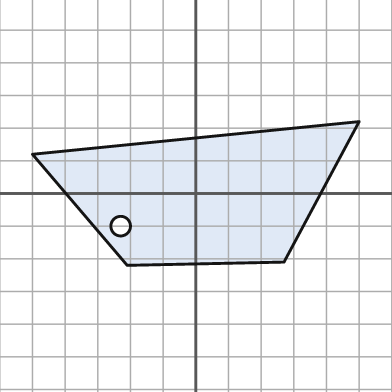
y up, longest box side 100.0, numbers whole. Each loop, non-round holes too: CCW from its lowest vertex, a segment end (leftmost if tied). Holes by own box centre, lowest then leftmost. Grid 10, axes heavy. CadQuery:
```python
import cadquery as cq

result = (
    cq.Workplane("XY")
    .moveTo(-21.0, -22.0)
    .lineTo(27.0, -21.0)
    .lineTo(50.0, 22.0)
    .lineTo(-50.0, 12.0)
    .close()
    .moveTo(-23.0, -10.0)
    .circle(3.0)
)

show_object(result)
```